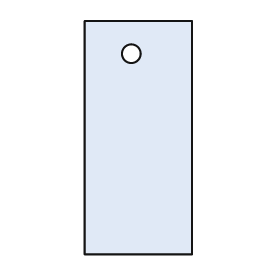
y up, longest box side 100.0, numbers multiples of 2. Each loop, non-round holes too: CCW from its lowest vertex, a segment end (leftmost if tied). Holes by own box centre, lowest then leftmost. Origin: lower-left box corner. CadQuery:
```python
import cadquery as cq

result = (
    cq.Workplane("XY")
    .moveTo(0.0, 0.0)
    .lineTo(46.0, 0.0)
    .lineTo(46.0, 100.0)
    .lineTo(0.0, 100.0)
    .close()
    .moveTo(20.0, 86.0)
    .circle(4.0)
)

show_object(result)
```